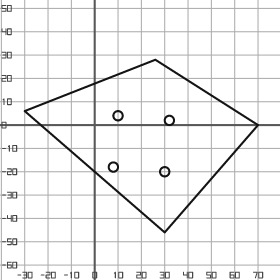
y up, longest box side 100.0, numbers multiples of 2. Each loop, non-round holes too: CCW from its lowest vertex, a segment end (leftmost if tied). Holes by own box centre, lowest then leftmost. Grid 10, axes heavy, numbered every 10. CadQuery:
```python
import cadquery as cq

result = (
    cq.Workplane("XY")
    .moveTo(30.0, -46.0)
    .lineTo(70.0, 0.0)
    .lineTo(26.0, 28.0)
    .lineTo(-30.0, 6.0)
    .close()
    .moveTo(30.0, -20.0)
    .circle(2.0)
    .moveTo(8.0, -18.0)
    .circle(2.0)
    .moveTo(32.0, 2.0)
    .circle(2.0)
    .moveTo(10.0, 4.0)
    .circle(2.0)
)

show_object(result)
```